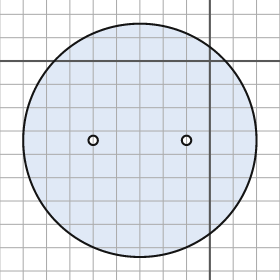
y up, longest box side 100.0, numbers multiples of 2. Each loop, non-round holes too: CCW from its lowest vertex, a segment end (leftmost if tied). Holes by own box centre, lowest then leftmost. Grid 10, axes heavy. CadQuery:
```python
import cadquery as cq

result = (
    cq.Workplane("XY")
    .moveTo(-30.0, -34.0)
    .circle(50.0)
    .moveTo(-50.0, -34.0)
    .circle(2.0)
    .moveTo(-10.0, -34.0)
    .circle(2.0)
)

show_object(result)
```